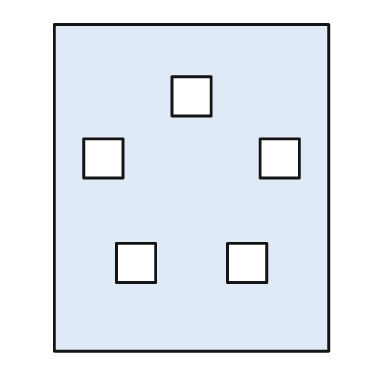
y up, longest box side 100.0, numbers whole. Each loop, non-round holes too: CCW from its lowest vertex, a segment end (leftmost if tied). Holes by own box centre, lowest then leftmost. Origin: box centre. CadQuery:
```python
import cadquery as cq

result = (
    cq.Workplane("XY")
    .moveTo(-42.0, -50.0)
    .lineTo(42.0, -50.0)
    .lineTo(42.0, 50.0)
    .lineTo(-42.0, 50.0)
    .close()
    .moveTo(-23.0, -29.0)
    .lineTo(-11.0, -29.0)
    .lineTo(-11.0, -17.0)
    .lineTo(-23.0, -17.0)
    .close()
    .moveTo(11.0, -29.0)
    .lineTo(23.0, -29.0)
    .lineTo(23.0, -17.0)
    .lineTo(11.0, -17.0)
    .close()
    .moveTo(-33.0, 3.0)
    .lineTo(-21.0, 3.0)
    .lineTo(-21.0, 15.0)
    .lineTo(-33.0, 15.0)
    .close()
    .moveTo(21.0, 3.0)
    .lineTo(33.0, 3.0)
    .lineTo(33.0, 15.0)
    .lineTo(21.0, 15.0)
    .close()
    .moveTo(-6.0, 22.0)
    .lineTo(6.0, 22.0)
    .lineTo(6.0, 34.0)
    .lineTo(-6.0, 34.0)
    .close()
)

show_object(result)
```